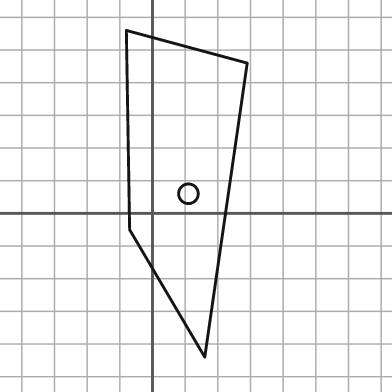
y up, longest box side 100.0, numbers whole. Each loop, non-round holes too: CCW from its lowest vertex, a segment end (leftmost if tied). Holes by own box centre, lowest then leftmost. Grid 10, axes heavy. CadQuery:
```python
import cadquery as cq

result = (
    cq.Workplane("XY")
    .moveTo(16.0, -44.0)
    .lineTo(29.0, 46.0)
    .lineTo(-8.0, 56.0)
    .lineTo(-7.0, -5.0)
    .close()
    .moveTo(11.0, 6.0)
    .circle(3.0)
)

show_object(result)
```